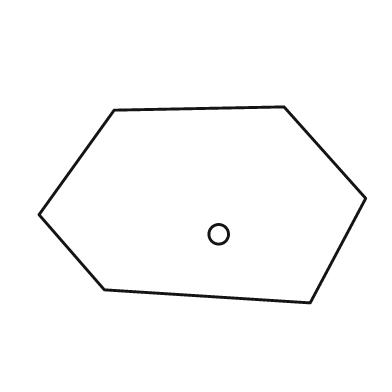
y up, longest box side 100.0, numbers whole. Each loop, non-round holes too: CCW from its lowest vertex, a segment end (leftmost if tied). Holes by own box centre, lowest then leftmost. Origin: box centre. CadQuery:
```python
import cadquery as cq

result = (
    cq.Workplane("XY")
    .moveTo(33.0, -30.0)
    .lineTo(50.0, 2.0)
    .lineTo(25.0, 30.0)
    .lineTo(-27.0, 29.0)
    .lineTo(-50.0, -3.0)
    .lineTo(-30.0, -26.0)
    .close()
    .moveTo(5.0, -9.0)
    .circle(3.0)
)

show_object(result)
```